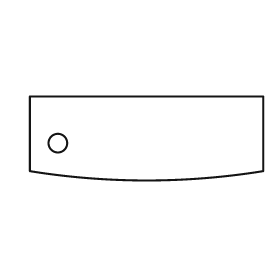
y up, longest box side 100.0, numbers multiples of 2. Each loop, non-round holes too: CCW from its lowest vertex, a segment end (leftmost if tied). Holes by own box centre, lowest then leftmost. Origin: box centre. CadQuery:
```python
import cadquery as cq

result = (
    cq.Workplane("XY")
    .moveTo(-50.0, -14.0)
    .threePointArc((0.0, -18.0), (50.0, -14.0))
    .lineTo(50.0, 18.0)
    .lineTo(-50.0, 18.0)
    .close()
    .moveTo(-38.0, -2.0)
    .circle(4.0)
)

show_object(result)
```